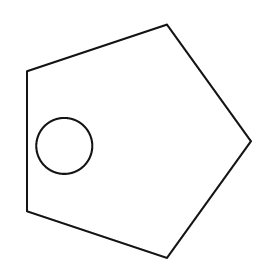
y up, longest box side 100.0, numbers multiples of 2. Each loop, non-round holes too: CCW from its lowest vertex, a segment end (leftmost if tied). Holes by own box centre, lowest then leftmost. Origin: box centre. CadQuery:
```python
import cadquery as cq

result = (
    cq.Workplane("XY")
    .moveTo(12.0, -50.0)
    .lineTo(48.0, 0.0)
    .lineTo(12.0, 50.0)
    .lineTo(-48.0, 30.0)
    .lineTo(-48.0, -30.0)
    .close()
    .moveTo(-32.0, -2.0)
    .circle(12.0)
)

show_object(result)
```